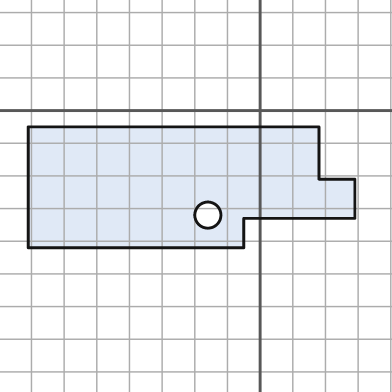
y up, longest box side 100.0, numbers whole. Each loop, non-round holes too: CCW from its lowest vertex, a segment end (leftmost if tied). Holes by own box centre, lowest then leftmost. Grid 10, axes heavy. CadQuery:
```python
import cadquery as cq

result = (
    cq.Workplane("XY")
    .moveTo(-71.0, -42.0)
    .lineTo(-5.0, -42.0)
    .lineTo(-5.0, -33.0)
    .lineTo(29.0, -33.0)
    .lineTo(29.0, -21.0)
    .lineTo(18.0, -21.0)
    .lineTo(18.0, -5.0)
    .lineTo(-71.0, -5.0)
    .close()
    .moveTo(-16.0, -32.0)
    .circle(4.0)
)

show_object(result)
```